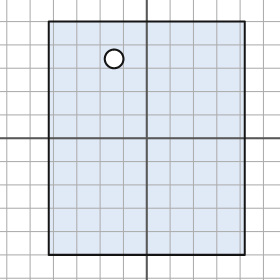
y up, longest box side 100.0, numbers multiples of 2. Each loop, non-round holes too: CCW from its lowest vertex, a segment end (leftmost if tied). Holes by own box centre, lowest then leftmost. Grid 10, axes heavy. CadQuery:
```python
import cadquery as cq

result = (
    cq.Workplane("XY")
    .moveTo(-42.0, -50.0)
    .lineTo(42.0, -50.0)
    .lineTo(42.0, 50.0)
    .lineTo(-42.0, 50.0)
    .close()
    .moveTo(-14.0, 34.0)
    .circle(4.0)
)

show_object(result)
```